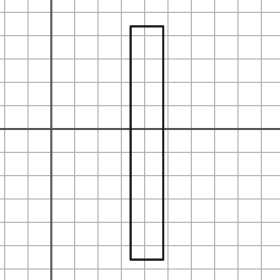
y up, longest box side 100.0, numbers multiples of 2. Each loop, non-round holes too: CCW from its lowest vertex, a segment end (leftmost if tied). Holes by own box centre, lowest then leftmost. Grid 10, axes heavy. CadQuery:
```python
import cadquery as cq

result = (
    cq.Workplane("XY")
    .moveTo(34.0, -56.0)
    .lineTo(48.0, -56.0)
    .lineTo(48.0, 44.0)
    .lineTo(34.0, 44.0)
    .close()
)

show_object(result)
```